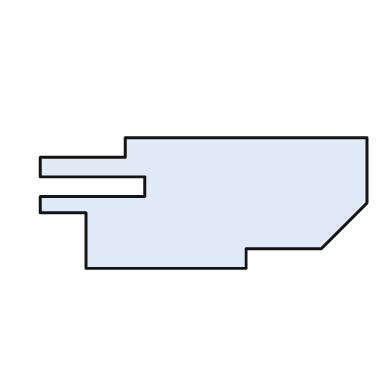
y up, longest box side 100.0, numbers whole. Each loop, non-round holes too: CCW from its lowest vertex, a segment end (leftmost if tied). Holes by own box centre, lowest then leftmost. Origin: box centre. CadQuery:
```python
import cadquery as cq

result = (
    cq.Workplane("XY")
    .moveTo(-36.0, -20.0)
    .lineTo(13.0, -20.0)
    .lineTo(13.0, -14.0)
    .lineTo(36.0, -14.0)
    .lineTo(50.0, 0.0)
    .lineTo(50.0, 20.0)
    .lineTo(-24.0, 20.0)
    .lineTo(-24.0, 14.0)
    .lineTo(-50.0, 14.0)
    .lineTo(-50.0, 8.0)
    .lineTo(-18.0, 8.0)
    .lineTo(-18.0, 2.0)
    .lineTo(-50.0, 2.0)
    .lineTo(-50.0, -3.0)
    .lineTo(-36.0, -3.0)
    .close()
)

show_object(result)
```